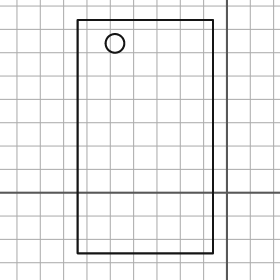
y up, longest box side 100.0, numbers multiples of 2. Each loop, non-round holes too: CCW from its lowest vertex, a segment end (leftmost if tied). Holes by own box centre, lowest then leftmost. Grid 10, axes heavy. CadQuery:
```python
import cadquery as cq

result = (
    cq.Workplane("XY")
    .moveTo(-64.0, -26.0)
    .lineTo(-6.0, -26.0)
    .lineTo(-6.0, 74.0)
    .lineTo(-64.0, 74.0)
    .close()
    .moveTo(-48.0, 64.0)
    .circle(4.0)
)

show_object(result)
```